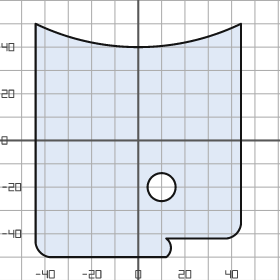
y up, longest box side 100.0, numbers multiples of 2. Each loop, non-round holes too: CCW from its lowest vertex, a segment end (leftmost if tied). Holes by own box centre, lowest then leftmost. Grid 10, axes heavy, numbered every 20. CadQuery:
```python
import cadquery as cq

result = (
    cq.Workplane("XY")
    .moveTo(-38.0, -50.0)
    .lineTo(12.0, -50.0)
    .threePointArc((14.0, -46.0), (12.0, -42.0))
    .lineTo(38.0, -42.0)
    .threePointArc((42.0, -40.0), (44.0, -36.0))
    .lineTo(44.0, 50.0)
    .threePointArc((0.0, 40.0), (-44.0, 50.0))
    .lineTo(-44.0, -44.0)
    .threePointArc((-42.0, -48.0), (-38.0, -50.0))
    .close()
    .moveTo(10.0, -20.0)
    .circle(6.0)
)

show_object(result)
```